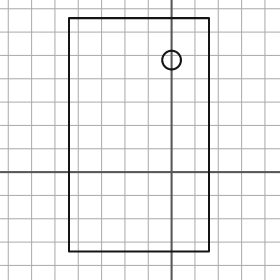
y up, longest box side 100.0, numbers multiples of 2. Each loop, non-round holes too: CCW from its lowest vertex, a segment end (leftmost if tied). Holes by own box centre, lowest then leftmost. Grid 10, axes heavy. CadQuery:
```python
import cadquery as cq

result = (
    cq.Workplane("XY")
    .moveTo(-44.0, -34.0)
    .lineTo(16.0, -34.0)
    .lineTo(16.0, 66.0)
    .lineTo(-44.0, 66.0)
    .close()
    .moveTo(0.0, 48.0)
    .circle(4.0)
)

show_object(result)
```